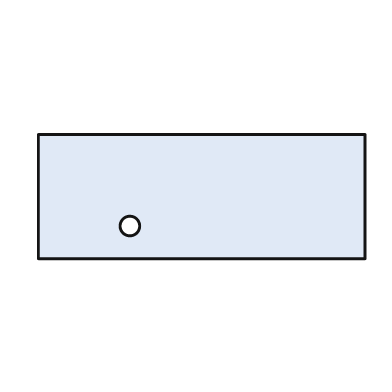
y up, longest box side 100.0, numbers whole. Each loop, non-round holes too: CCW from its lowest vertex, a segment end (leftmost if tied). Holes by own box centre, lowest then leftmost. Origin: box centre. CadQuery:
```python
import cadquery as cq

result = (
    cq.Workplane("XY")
    .moveTo(-50.0, -19.0)
    .lineTo(50.0, -19.0)
    .lineTo(50.0, 19.0)
    .lineTo(-50.0, 19.0)
    .close()
    .moveTo(-22.0, -9.0)
    .circle(3.0)
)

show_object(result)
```